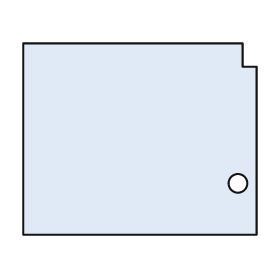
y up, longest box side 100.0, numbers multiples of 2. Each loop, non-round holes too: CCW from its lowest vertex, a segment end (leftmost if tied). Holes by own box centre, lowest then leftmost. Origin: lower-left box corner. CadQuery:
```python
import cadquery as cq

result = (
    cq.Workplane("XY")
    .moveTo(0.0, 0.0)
    .lineTo(100.0, 0.0)
    .lineTo(100.0, 72.0)
    .lineTo(94.0, 72.0)
    .lineTo(94.0, 82.0)
    .lineTo(0.0, 82.0)
    .close()
    .moveTo(92.0, 22.0)
    .circle(4.0)
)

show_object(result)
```